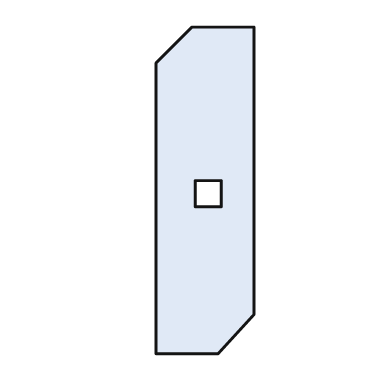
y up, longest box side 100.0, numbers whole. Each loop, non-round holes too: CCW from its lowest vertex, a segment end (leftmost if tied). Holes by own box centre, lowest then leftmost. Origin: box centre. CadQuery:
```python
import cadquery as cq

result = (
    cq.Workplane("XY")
    .moveTo(-15.0, -50.0)
    .lineTo(4.0, -50.0)
    .lineTo(15.0, -38.0)
    .lineTo(15.0, 50.0)
    .lineTo(-4.0, 50.0)
    .lineTo(-15.0, 39.0)
    .close()
    .moveTo(-3.0, -5.0)
    .lineTo(5.0, -5.0)
    .lineTo(5.0, 3.0)
    .lineTo(-3.0, 3.0)
    .close()
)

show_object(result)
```